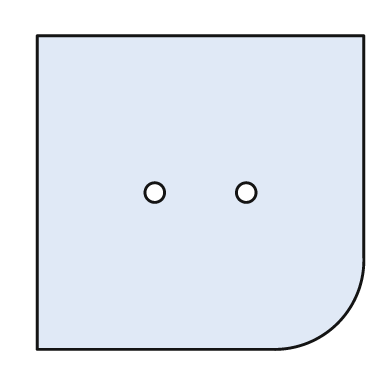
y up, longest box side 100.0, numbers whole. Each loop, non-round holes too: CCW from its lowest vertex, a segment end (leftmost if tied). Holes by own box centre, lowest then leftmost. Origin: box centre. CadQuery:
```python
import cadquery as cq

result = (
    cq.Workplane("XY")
    .moveTo(-50.0, -48.0)
    .lineTo(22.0, -48.0)
    .threePointArc((42.0, -40.0), (50.0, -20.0))
    .lineTo(50.0, 48.0)
    .lineTo(-50.0, 48.0)
    .close()
    .moveTo(-14.0, 0.0)
    .circle(3.0)
    .moveTo(14.0, 0.0)
    .circle(3.0)
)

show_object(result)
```